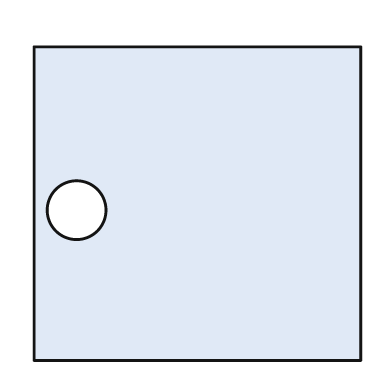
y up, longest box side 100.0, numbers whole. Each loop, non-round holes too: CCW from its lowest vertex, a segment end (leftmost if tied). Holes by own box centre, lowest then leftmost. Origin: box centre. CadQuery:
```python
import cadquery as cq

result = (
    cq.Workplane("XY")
    .moveTo(-50.0, -48.0)
    .lineTo(50.0, -48.0)
    .lineTo(50.0, 48.0)
    .lineTo(-50.0, 48.0)
    .close()
    .moveTo(-37.0, -2.0)
    .circle(9.0)
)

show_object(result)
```